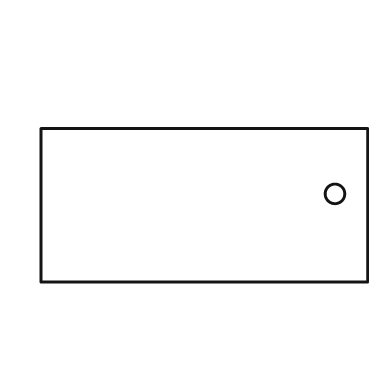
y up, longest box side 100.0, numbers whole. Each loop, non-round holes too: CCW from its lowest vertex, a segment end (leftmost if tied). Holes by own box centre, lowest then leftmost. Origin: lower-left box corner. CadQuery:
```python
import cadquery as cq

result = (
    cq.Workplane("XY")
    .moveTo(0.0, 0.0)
    .lineTo(100.0, 0.0)
    .lineTo(100.0, 47.0)
    .lineTo(0.0, 47.0)
    .close()
    .moveTo(90.0, 27.0)
    .circle(3.0)
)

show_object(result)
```